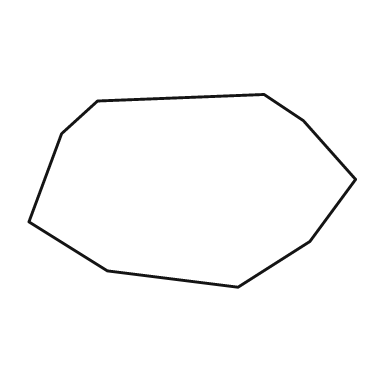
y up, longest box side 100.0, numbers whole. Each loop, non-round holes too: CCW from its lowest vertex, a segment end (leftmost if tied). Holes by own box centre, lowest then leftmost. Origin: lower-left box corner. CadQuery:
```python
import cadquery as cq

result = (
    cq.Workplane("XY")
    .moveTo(64.0, 0.0)
    .lineTo(86.0, 14.0)
    .lineTo(100.0, 33.0)
    .lineTo(84.0, 51.0)
    .lineTo(72.0, 59.0)
    .lineTo(21.0, 57.0)
    .lineTo(10.0, 47.0)
    .lineTo(0.0, 20.0)
    .lineTo(24.0, 5.0)
    .close()
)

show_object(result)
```